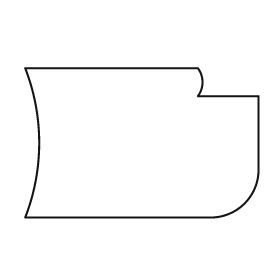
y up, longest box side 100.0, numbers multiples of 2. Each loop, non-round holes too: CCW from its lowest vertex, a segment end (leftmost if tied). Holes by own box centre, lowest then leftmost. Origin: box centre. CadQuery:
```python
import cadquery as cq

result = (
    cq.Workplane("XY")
    .moveTo(-50.0, -32.0)
    .lineTo(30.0, -32.0)
    .threePointArc((44.0, -26.0), (50.0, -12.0))
    .lineTo(50.0, 20.0)
    .lineTo(24.0, 20.0)
    .threePointArc((26.0, 26.0), (24.0, 32.0))
    .lineTo(-50.0, 32.0)
    .threePointArc((-44.0, 0.0), (-50.0, -32.0))
    .close()
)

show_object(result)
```